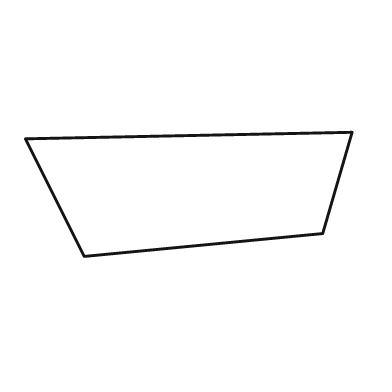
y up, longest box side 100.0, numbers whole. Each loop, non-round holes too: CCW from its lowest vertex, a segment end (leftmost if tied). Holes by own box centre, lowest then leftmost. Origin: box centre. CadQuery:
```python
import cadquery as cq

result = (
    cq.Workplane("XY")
    .moveTo(-32.0, -19.0)
    .lineTo(41.0, -12.0)
    .lineTo(50.0, 19.0)
    .lineTo(-50.0, 17.0)
    .close()
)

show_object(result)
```